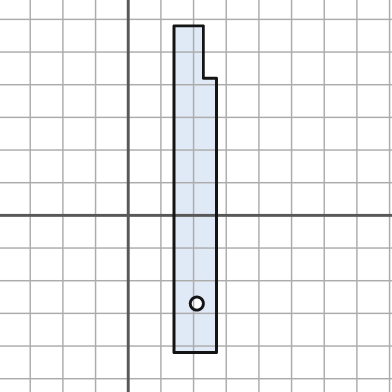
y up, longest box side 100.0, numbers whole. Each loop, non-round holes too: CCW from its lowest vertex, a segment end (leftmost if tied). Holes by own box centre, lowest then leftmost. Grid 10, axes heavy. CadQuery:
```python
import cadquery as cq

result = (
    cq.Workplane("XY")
    .moveTo(14.0, -42.0)
    .lineTo(27.0, -42.0)
    .lineTo(27.0, 42.0)
    .lineTo(23.0, 42.0)
    .lineTo(23.0, 58.0)
    .lineTo(14.0, 58.0)
    .close()
    .moveTo(21.0, -27.0)
    .circle(2.0)
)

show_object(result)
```